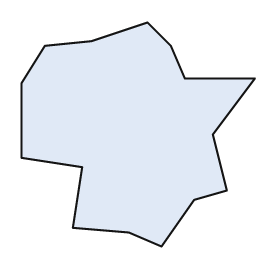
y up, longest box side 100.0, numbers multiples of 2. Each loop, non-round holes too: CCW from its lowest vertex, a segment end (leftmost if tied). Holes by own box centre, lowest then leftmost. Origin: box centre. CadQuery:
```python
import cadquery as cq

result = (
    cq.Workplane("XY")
    .moveTo(10.0, -48.0)
    .lineTo(24.0, -28.0)
    .lineTo(38.0, -24.0)
    .lineTo(32.0, 0.0)
    .lineTo(50.0, 24.0)
    .lineTo(20.0, 24.0)
    .lineTo(14.0, 38.0)
    .lineTo(4.0, 48.0)
    .lineTo(-20.0, 40.0)
    .lineTo(-40.0, 38.0)
    .lineTo(-50.0, 22.0)
    .lineTo(-50.0, -10.0)
    .lineTo(-24.0, -14.0)
    .lineTo(-28.0, -40.0)
    .lineTo(-4.0, -42.0)
    .close()
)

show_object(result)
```